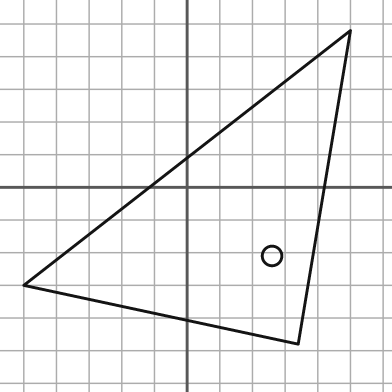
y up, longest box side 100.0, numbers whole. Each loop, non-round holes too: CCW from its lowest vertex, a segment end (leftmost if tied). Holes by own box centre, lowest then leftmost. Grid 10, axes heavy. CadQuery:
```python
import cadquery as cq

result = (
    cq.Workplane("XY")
    .moveTo(34.0, -48.0)
    .lineTo(50.0, 48.0)
    .lineTo(-50.0, -30.0)
    .close()
    .moveTo(26.0, -21.0)
    .circle(3.0)
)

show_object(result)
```